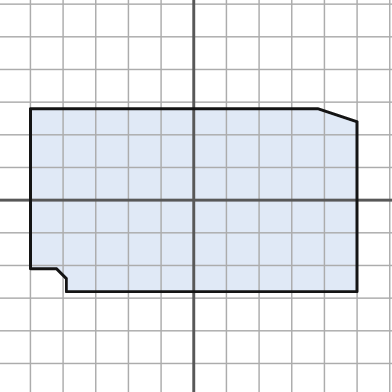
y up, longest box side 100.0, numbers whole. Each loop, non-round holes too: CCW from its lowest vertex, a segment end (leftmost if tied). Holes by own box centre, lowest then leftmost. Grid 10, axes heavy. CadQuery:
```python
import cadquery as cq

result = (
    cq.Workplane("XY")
    .moveTo(-39.0, -28.0)
    .lineTo(50.0, -28.0)
    .lineTo(50.0, 24.0)
    .lineTo(38.0, 28.0)
    .lineTo(-50.0, 28.0)
    .lineTo(-50.0, -21.0)
    .lineTo(-42.0, -21.0)
    .lineTo(-39.0, -24.0)
    .close()
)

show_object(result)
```